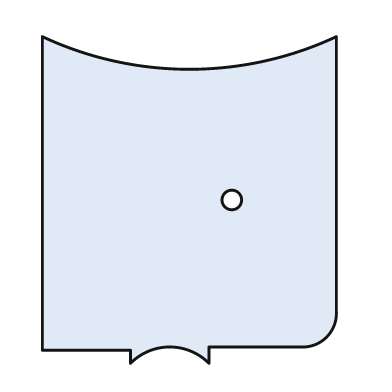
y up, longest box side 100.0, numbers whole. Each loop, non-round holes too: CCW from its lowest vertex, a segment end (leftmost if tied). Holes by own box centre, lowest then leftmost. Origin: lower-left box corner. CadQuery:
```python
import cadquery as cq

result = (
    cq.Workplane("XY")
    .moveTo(27.0, 0.0)
    .threePointArc((39.0, 5.0), (51.0, 0.0))
    .lineTo(51.0, 5.0)
    .lineTo(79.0, 5.0)
    .threePointArc((87.0, 8.0), (90.0, 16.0))
    .lineTo(90.0, 100.0)
    .threePointArc((45.0, 90.0), (0.0, 100.0))
    .lineTo(0.0, 4.0)
    .lineTo(27.0, 4.0)
    .close()
    .moveTo(58.0, 50.0)
    .circle(3.0)
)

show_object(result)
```